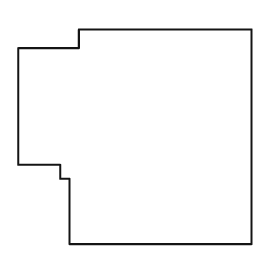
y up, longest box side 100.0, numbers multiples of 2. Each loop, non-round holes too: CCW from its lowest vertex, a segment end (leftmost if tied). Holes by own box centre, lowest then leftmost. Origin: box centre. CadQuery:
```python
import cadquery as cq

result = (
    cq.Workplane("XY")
    .moveTo(-28.0, -46.0)
    .lineTo(50.0, -46.0)
    .lineTo(50.0, 46.0)
    .lineTo(-24.0, 46.0)
    .lineTo(-24.0, 38.0)
    .lineTo(-50.0, 38.0)
    .lineTo(-50.0, -12.0)
    .lineTo(-32.0, -12.0)
    .lineTo(-32.0, -18.0)
    .lineTo(-28.0, -18.0)
    .close()
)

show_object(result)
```